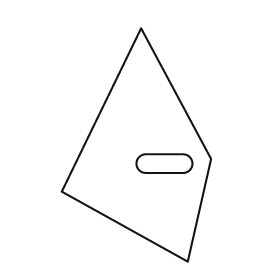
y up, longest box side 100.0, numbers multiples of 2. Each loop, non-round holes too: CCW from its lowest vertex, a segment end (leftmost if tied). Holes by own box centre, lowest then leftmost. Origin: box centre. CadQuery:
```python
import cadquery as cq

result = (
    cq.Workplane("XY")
    .moveTo(22.0, -50.0)
    .lineTo(32.0, -6.0)
    .lineTo(2.0, 50.0)
    .lineTo(-32.0, -20.0)
    .close()
    .moveTo(4.0, -12.0)
    .lineTo(20.0, -12.0)
    .threePointArc((24.0, -8.0), (20.0, -4.0))
    .lineTo(4.0, -4.0)
    .threePointArc((0.0, -8.0), (4.0, -12.0))
    .close()
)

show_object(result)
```